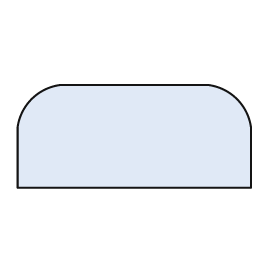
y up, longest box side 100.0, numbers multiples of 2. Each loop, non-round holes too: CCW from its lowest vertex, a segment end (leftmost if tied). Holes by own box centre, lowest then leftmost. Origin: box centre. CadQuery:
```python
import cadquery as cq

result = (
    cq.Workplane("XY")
    .moveTo(-50.0, -22.0)
    .lineTo(50.0, -22.0)
    .lineTo(50.0, 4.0)
    .threePointArc((44.0, 16.0), (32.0, 22.0))
    .lineTo(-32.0, 22.0)
    .threePointArc((-44.0, 16.0), (-50.0, 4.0))
    .close()
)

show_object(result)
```